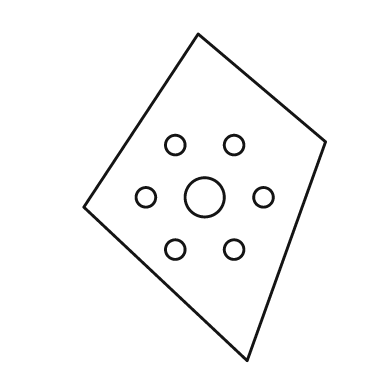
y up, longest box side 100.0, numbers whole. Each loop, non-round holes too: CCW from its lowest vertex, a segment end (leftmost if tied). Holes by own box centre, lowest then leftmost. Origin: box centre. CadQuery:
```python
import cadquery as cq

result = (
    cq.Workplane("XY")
    .moveTo(13.0, -50.0)
    .lineTo(37.0, 17.0)
    .lineTo(-2.0, 50.0)
    .lineTo(-37.0, -3.0)
    .close()
    .moveTo(-9.0, -16.0)
    .circle(3.0)
    .moveTo(9.0, -16.0)
    .circle(3.0)
    .moveTo(-18.0, 0.0)
    .circle(3.0)
    .moveTo(0.0, 0.0)
    .circle(6.0)
    .moveTo(18.0, 0.0)
    .circle(3.0)
    .moveTo(-9.0, 16.0)
    .circle(3.0)
    .moveTo(9.0, 16.0)
    .circle(3.0)
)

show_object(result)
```